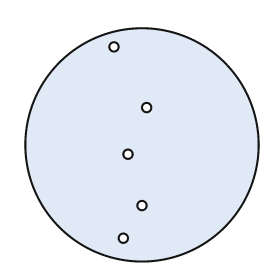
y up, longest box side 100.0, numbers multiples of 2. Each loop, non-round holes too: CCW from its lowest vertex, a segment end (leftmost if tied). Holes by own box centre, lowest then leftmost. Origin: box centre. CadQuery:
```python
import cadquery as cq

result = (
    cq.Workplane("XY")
    .moveTo(0.0, 0.0)
    .circle(50.0)
    .moveTo(-8.0, -40.0)
    .circle(2.0)
    .moveTo(0.0, -26.0)
    .circle(2.0)
    .moveTo(-6.0, -4.0)
    .circle(2.0)
    .moveTo(2.0, 16.0)
    .circle(2.0)
    .moveTo(-12.0, 42.0)
    .circle(2.0)
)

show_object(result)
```